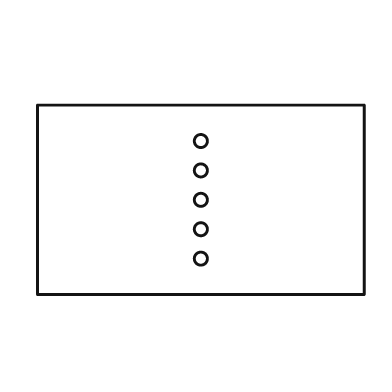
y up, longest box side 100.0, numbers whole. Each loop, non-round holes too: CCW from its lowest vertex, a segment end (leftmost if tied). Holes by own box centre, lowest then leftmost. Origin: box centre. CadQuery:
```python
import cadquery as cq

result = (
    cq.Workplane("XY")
    .moveTo(-50.0, -29.0)
    .lineTo(50.0, -29.0)
    .lineTo(50.0, 29.0)
    .lineTo(-50.0, 29.0)
    .close()
    .moveTo(0.0, -18.0)
    .circle(2.0)
    .moveTo(0.0, -9.0)
    .circle(2.0)
    .moveTo(0.0, 0.0)
    .circle(2.0)
    .moveTo(0.0, 9.0)
    .circle(2.0)
    .moveTo(0.0, 18.0)
    .circle(2.0)
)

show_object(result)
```